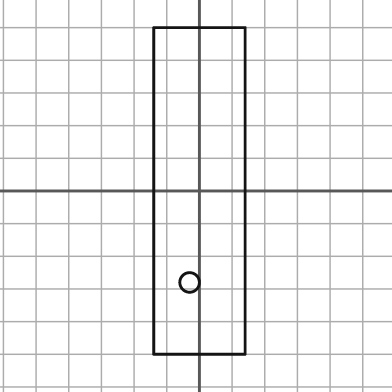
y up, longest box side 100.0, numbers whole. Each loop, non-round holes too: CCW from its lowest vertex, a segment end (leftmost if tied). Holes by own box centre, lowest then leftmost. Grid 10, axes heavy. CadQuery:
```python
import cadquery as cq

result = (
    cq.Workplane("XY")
    .moveTo(-14.0, -50.0)
    .lineTo(14.0, -50.0)
    .lineTo(14.0, 50.0)
    .lineTo(-14.0, 50.0)
    .close()
    .moveTo(-3.0, -28.0)
    .circle(3.0)
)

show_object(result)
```